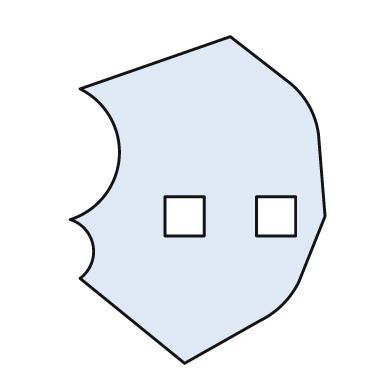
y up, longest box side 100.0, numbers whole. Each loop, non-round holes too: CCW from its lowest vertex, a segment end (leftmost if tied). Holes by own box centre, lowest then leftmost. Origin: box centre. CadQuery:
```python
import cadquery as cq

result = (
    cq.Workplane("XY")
    .moveTo(-4.0, -50.0)
    .lineTo(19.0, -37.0)
    .threePointArc((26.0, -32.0), (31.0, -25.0))
    .lineTo(39.0, -5.0)
    .lineTo(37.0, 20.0)
    .threePointArc((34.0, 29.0), (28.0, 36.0))
    .lineTo(10.0, 50.0)
    .lineTo(-36.0, 34.0)
    .threePointArc((-24.0, 13.0), (-39.0, -6.0))
    .threePointArc((-32.0, -14.0), (-36.0, -24.0))
    .close()
    .moveTo(-10.0, -11.0)
    .lineTo(2.0, -11.0)
    .lineTo(2.0, 1.0)
    .lineTo(-10.0, 1.0)
    .close()
    .moveTo(18.0, -11.0)
    .lineTo(30.0, -11.0)
    .lineTo(30.0, 1.0)
    .lineTo(18.0, 1.0)
    .close()
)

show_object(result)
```